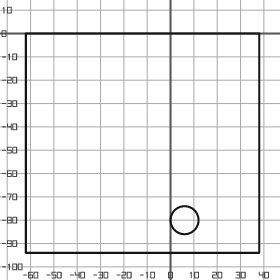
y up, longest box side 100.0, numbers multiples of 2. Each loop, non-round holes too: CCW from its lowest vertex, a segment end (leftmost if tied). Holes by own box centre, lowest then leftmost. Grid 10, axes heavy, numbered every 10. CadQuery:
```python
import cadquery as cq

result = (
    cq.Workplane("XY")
    .moveTo(-62.0, -94.0)
    .lineTo(38.0, -94.0)
    .lineTo(38.0, 0.0)
    .lineTo(-62.0, 0.0)
    .close()
    .moveTo(6.0, -80.0)
    .circle(6.0)
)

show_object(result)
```